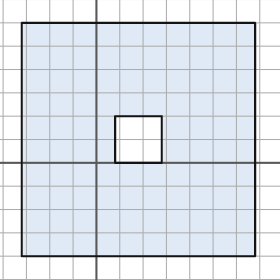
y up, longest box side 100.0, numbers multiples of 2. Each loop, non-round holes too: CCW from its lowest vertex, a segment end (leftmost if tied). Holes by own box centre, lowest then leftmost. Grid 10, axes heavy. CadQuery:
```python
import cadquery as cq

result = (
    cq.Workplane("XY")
    .moveTo(-32.0, -40.0)
    .lineTo(68.0, -40.0)
    .lineTo(68.0, 60.0)
    .lineTo(-32.0, 60.0)
    .close()
    .moveTo(8.0, 0.0)
    .lineTo(28.0, 0.0)
    .lineTo(28.0, 20.0)
    .lineTo(8.0, 20.0)
    .close()
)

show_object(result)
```